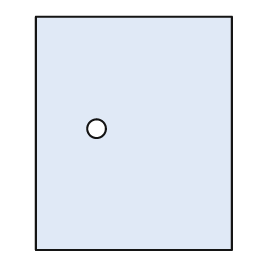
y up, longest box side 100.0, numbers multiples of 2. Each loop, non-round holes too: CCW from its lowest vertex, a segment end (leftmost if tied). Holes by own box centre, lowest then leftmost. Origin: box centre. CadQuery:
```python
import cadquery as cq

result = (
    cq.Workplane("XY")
    .moveTo(-42.0, -50.0)
    .lineTo(42.0, -50.0)
    .lineTo(42.0, 50.0)
    .lineTo(-42.0, 50.0)
    .close()
    .moveTo(-16.0, 2.0)
    .circle(4.0)
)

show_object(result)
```